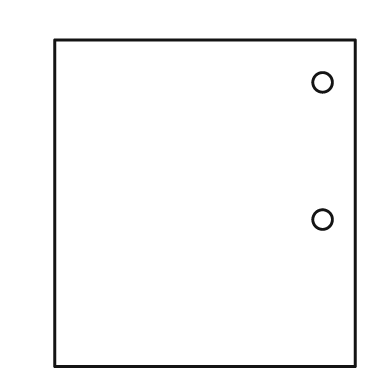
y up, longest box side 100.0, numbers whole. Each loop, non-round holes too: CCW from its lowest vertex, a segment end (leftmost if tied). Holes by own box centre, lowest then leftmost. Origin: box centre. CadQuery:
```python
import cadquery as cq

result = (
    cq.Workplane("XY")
    .moveTo(-46.0, -50.0)
    .lineTo(46.0, -50.0)
    .lineTo(46.0, 50.0)
    .lineTo(-46.0, 50.0)
    .close()
    .moveTo(36.0, -5.0)
    .circle(3.0)
    .moveTo(36.0, 37.0)
    .circle(3.0)
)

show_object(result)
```